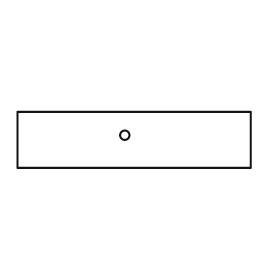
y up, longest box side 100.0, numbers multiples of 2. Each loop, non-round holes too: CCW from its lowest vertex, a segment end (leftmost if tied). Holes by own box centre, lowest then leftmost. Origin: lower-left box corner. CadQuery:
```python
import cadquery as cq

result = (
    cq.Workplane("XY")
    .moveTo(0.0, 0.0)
    .lineTo(100.0, 0.0)
    .lineTo(100.0, 24.0)
    .lineTo(0.0, 24.0)
    .close()
    .moveTo(46.0, 14.0)
    .circle(2.0)
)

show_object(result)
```